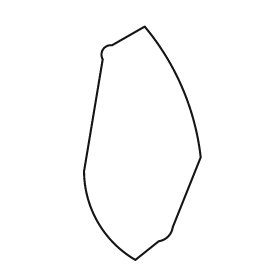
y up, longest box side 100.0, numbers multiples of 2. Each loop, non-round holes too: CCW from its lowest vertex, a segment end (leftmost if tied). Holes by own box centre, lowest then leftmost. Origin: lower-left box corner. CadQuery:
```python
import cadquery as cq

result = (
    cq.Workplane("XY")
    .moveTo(22.0, 0.0)
    .lineTo(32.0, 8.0)
    .threePointArc((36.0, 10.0), (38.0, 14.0))
    .lineTo(50.0, 44.0)
    .threePointArc((42.0, 74.0), (26.0, 100.0))
    .lineTo(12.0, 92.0)
    .threePointArc((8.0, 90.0), (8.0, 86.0))
    .lineTo(0.0, 38.0)
    .threePointArc((6.0, 16.0), (22.0, 0.0))
    .close()
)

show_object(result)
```